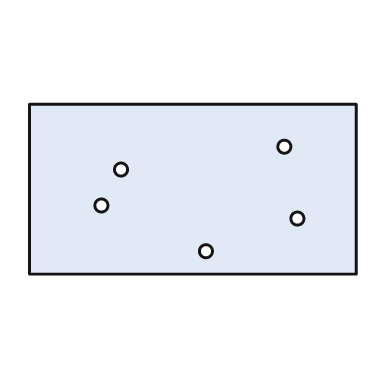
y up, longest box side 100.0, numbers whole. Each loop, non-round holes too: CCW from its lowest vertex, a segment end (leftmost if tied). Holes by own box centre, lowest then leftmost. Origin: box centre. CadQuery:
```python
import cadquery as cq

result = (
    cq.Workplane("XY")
    .moveTo(-50.0, -26.0)
    .lineTo(50.0, -26.0)
    .lineTo(50.0, 26.0)
    .lineTo(-50.0, 26.0)
    .close()
    .moveTo(4.0, -19.0)
    .circle(2.0)
    .moveTo(32.0, -9.0)
    .circle(2.0)
    .moveTo(-28.0, -5.0)
    .circle(2.0)
    .moveTo(-22.0, 6.0)
    .circle(2.0)
    .moveTo(28.0, 13.0)
    .circle(2.0)
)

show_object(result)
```